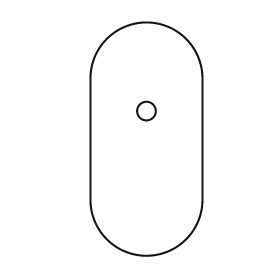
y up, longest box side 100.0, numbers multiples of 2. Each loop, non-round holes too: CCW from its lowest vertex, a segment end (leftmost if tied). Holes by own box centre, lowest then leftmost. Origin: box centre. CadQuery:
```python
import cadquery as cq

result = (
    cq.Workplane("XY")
    .moveTo(-24.0, -26.0)
    .threePointArc((0.0, -50.0), (24.0, -26.0))
    .lineTo(24.0, 26.0)
    .threePointArc((0.0, 50.0), (-24.0, 26.0))
    .close()
    .moveTo(0.0, 12.0)
    .circle(4.0)
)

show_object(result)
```